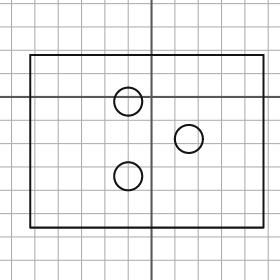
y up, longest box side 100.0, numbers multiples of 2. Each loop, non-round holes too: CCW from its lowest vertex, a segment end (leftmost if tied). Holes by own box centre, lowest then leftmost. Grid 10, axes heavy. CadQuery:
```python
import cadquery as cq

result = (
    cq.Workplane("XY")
    .moveTo(-52.0, -56.0)
    .lineTo(48.0, -56.0)
    .lineTo(48.0, 18.0)
    .lineTo(-52.0, 18.0)
    .close()
    .moveTo(-10.0, -34.0)
    .circle(6.0)
    .moveTo(16.0, -18.0)
    .circle(6.0)
    .moveTo(-10.0, -2.0)
    .circle(6.0)
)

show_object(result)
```